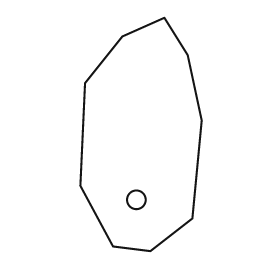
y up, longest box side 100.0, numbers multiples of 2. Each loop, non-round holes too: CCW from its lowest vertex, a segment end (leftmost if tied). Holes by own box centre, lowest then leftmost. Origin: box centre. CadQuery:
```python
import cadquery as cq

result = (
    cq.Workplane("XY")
    .moveTo(4.0, -50.0)
    .lineTo(22.0, -36.0)
    .lineTo(26.0, 6.0)
    .lineTo(20.0, 34.0)
    .lineTo(10.0, 50.0)
    .lineTo(-8.0, 42.0)
    .lineTo(-24.0, 22.0)
    .lineTo(-26.0, -22.0)
    .lineTo(-12.0, -48.0)
    .close()
    .moveTo(-2.0, -28.0)
    .circle(4.0)
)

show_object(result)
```